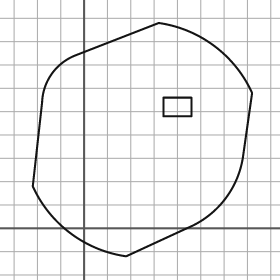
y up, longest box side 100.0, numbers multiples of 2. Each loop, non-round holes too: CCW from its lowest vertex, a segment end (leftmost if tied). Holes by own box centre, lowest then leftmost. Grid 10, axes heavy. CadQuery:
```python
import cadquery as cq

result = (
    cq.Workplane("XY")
    .moveTo(18.0, -12.0)
    .lineTo(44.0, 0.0)
    .threePointArc((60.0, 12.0), (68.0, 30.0))
    .lineTo(72.0, 58.0)
    .threePointArc((56.0, 78.0), (32.0, 88.0))
    .lineTo(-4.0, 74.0)
    .threePointArc((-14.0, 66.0), (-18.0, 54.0))
    .lineTo(-22.0, 18.0)
    .threePointArc((-6.0, -2.0), (18.0, -12.0))
    .close()
    .moveTo(34.0, 48.0)
    .lineTo(46.0, 48.0)
    .lineTo(46.0, 56.0)
    .lineTo(34.0, 56.0)
    .close()
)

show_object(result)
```